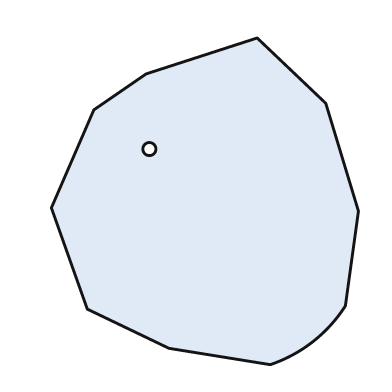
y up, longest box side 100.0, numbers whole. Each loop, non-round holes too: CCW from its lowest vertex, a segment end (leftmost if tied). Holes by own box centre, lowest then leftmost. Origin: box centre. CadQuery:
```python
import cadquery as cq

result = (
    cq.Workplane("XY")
    .moveTo(20.0, -50.0)
    .threePointArc((33.0, -43.0), (43.0, -32.0))
    .lineTo(47.0, -3.0)
    .lineTo(37.0, 30.0)
    .lineTo(16.0, 50.0)
    .lineTo(-18.0, 39.0)
    .lineTo(-34.0, 28.0)
    .lineTo(-47.0, -2.0)
    .lineTo(-36.0, -33.0)
    .lineTo(-11.0, -45.0)
    .close()
    .moveTo(-17.0, 16.0)
    .circle(2.0)
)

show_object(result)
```